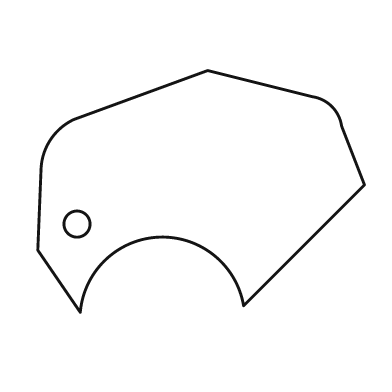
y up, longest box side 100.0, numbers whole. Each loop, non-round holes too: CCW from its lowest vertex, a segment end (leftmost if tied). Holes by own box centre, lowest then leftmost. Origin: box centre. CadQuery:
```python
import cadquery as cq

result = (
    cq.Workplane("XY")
    .moveTo(-37.0, -37.0)
    .threePointArc((-13.0, -14.0), (13.0, -35.0))
    .lineTo(50.0, 2.0)
    .lineTo(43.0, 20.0)
    .threePointArc((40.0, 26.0), (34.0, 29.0))
    .lineTo(2.0, 37.0)
    .lineTo(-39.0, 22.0)
    .threePointArc((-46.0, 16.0), (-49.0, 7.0))
    .lineTo(-50.0, -18.0)
    .close()
    .moveTo(-38.0, -10.0)
    .circle(4.0)
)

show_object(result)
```